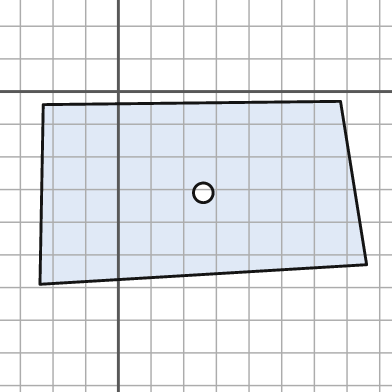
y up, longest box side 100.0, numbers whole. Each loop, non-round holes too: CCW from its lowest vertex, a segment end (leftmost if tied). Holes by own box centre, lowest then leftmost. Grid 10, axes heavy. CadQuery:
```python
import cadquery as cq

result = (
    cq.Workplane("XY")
    .moveTo(-24.0, -59.0)
    .lineTo(76.0, -53.0)
    .lineTo(68.0, -3.0)
    .lineTo(-23.0, -4.0)
    .close()
    .moveTo(26.0, -31.0)
    .circle(3.0)
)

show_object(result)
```